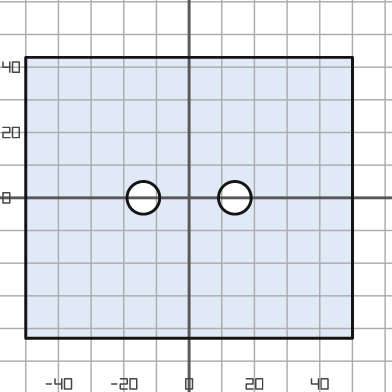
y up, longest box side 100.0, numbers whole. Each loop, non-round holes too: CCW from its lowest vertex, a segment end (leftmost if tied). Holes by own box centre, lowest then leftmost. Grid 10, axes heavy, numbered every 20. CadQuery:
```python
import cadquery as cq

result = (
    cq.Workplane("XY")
    .moveTo(-50.0, -43.0)
    .lineTo(50.0, -43.0)
    .lineTo(50.0, 43.0)
    .lineTo(-50.0, 43.0)
    .close()
    .moveTo(-14.0, 0.0)
    .circle(5.0)
    .moveTo(14.0, 0.0)
    .circle(5.0)
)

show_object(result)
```